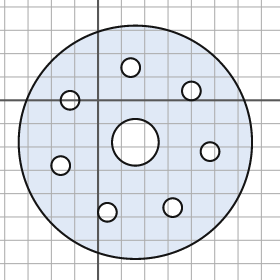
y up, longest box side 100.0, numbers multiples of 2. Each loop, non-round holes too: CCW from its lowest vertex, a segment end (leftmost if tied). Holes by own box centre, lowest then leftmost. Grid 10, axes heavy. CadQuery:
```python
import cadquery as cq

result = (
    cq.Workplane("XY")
    .moveTo(16.0, -18.0)
    .circle(50.0)
    .moveTo(4.0, -48.0)
    .circle(4.0)
    .moveTo(32.0, -46.0)
    .circle(4.0)
    .moveTo(-16.0, -28.0)
    .circle(4.0)
    .moveTo(48.0, -22.0)
    .circle(4.0)
    .moveTo(16.0, -18.0)
    .circle(10.0)
    .moveTo(-12.0, 0.0)
    .circle(4.0)
    .moveTo(40.0, 4.0)
    .circle(4.0)
    .moveTo(14.0, 14.0)
    .circle(4.0)
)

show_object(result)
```